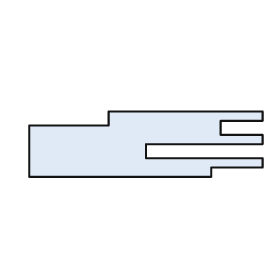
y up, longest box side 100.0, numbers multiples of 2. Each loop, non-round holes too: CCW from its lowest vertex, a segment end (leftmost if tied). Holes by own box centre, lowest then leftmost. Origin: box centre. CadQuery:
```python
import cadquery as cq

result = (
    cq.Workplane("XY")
    .moveTo(-50.0, -14.0)
    .lineTo(28.0, -14.0)
    .lineTo(28.0, -10.0)
    .lineTo(50.0, -10.0)
    .lineTo(50.0, -6.0)
    .lineTo(0.0, -6.0)
    .lineTo(0.0, 0.0)
    .lineTo(50.0, 0.0)
    .lineTo(50.0, 4.0)
    .lineTo(32.0, 4.0)
    .lineTo(32.0, 10.0)
    .lineTo(50.0, 10.0)
    .lineTo(50.0, 14.0)
    .lineTo(-16.0, 14.0)
    .lineTo(-16.0, 8.0)
    .lineTo(-50.0, 8.0)
    .close()
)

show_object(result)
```